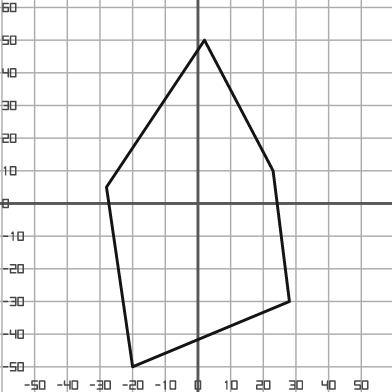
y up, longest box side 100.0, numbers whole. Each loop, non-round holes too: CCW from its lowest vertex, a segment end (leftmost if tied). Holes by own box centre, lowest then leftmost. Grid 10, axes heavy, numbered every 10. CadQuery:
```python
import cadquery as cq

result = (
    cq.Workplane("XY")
    .moveTo(-20.0, -50.0)
    .lineTo(28.0, -30.0)
    .lineTo(23.0, 10.0)
    .lineTo(2.0, 50.0)
    .lineTo(-28.0, 5.0)
    .close()
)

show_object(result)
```